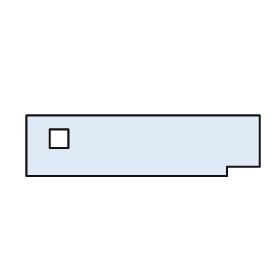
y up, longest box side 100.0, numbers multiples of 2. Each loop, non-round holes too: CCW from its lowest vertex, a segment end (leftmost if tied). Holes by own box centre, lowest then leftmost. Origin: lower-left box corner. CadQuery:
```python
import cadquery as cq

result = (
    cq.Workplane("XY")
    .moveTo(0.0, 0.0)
    .lineTo(86.0, 0.0)
    .lineTo(86.0, 4.0)
    .lineTo(100.0, 4.0)
    .lineTo(100.0, 26.0)
    .lineTo(0.0, 26.0)
    .close()
    .moveTo(10.0, 12.0)
    .lineTo(18.0, 12.0)
    .lineTo(18.0, 20.0)
    .lineTo(10.0, 20.0)
    .close()
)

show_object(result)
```